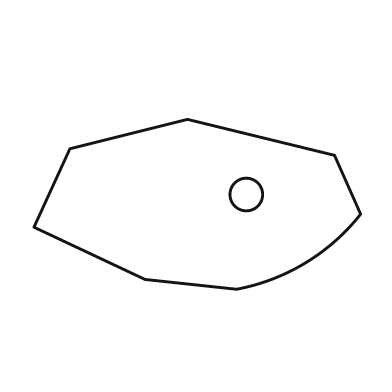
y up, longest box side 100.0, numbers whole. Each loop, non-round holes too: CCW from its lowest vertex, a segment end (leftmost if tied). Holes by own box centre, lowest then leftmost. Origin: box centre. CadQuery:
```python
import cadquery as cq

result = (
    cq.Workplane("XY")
    .moveTo(12.0, -26.0)
    .threePointArc((33.0, -18.0), (50.0, -3.0))
    .lineTo(42.0, 15.0)
    .lineTo(-3.0, 26.0)
    .lineTo(-39.0, 17.0)
    .lineTo(-50.0, -7.0)
    .lineTo(-16.0, -23.0)
    .close()
    .moveTo(15.0, 3.0)
    .circle(5.0)
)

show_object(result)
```